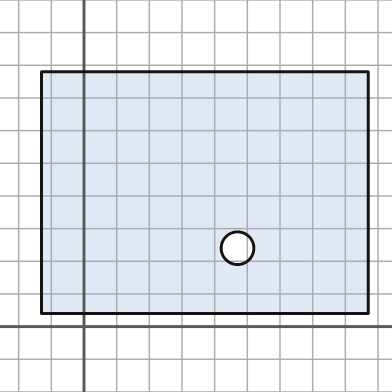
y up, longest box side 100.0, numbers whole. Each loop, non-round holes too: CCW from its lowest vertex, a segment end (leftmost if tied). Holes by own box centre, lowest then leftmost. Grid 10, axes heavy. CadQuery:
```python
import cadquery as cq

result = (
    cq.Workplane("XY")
    .moveTo(-13.0, 4.0)
    .lineTo(87.0, 4.0)
    .lineTo(87.0, 78.0)
    .lineTo(-13.0, 78.0)
    .close()
    .moveTo(47.0, 24.0)
    .circle(5.0)
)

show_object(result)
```